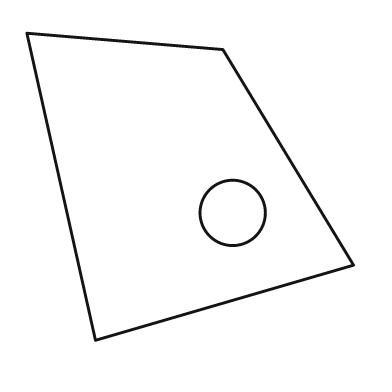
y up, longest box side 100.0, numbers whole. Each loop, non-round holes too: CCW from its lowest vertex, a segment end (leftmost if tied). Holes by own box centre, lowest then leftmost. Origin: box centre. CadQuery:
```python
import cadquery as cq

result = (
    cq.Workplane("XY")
    .moveTo(-29.0, -47.0)
    .lineTo(50.0, -24.0)
    .lineTo(10.0, 42.0)
    .lineTo(-50.0, 47.0)
    .close()
    .moveTo(13.0, -8.0)
    .circle(10.0)
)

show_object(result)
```